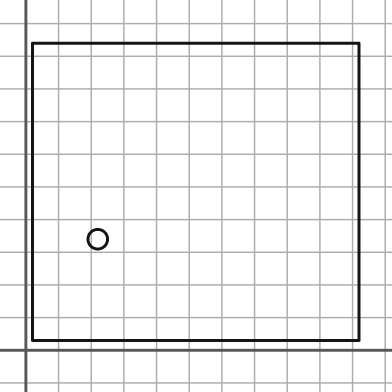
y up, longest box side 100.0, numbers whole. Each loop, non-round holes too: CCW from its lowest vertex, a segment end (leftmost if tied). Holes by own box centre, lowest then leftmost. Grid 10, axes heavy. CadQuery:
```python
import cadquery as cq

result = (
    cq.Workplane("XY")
    .moveTo(2.0, 3.0)
    .lineTo(102.0, 3.0)
    .lineTo(102.0, 94.0)
    .lineTo(2.0, 94.0)
    .close()
    .moveTo(22.0, 34.0)
    .circle(3.0)
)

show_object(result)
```